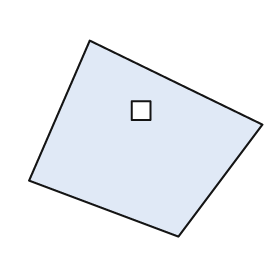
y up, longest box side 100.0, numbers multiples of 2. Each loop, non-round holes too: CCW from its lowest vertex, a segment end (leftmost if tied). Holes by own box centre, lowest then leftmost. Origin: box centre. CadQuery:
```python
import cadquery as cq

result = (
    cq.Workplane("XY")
    .moveTo(14.0, -42.0)
    .lineTo(50.0, 6.0)
    .lineTo(-24.0, 42.0)
    .lineTo(-50.0, -18.0)
    .close()
    .moveTo(-6.0, 8.0)
    .lineTo(2.0, 8.0)
    .lineTo(2.0, 16.0)
    .lineTo(-6.0, 16.0)
    .close()
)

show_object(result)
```